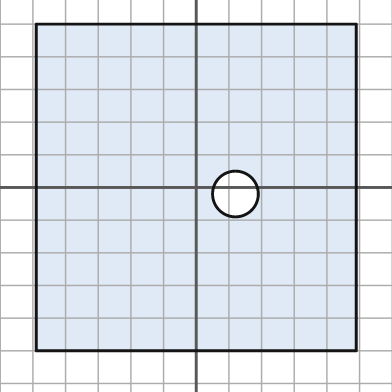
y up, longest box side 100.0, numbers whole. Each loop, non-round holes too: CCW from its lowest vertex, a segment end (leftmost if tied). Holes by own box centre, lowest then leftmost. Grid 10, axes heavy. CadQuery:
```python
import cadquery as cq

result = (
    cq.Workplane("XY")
    .moveTo(-49.0, -50.0)
    .lineTo(49.0, -50.0)
    .lineTo(49.0, 50.0)
    .lineTo(-49.0, 50.0)
    .close()
    .moveTo(12.0, -2.0)
    .circle(7.0)
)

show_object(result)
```